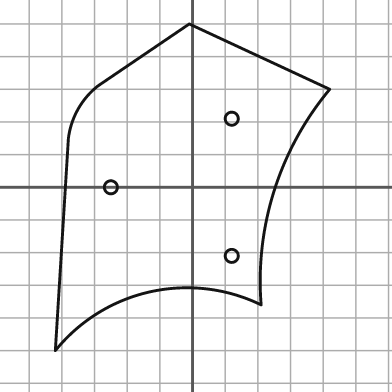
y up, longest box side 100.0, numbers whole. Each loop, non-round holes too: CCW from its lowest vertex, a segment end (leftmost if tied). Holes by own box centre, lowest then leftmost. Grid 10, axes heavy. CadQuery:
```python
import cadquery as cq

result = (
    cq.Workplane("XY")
    .moveTo(-42.0, -50.0)
    .threePointArc((-13.0, -32.0), (21.0, -36.0))
    .threePointArc((25.0, -1.0), (42.0, 30.0))
    .lineTo(-1.0, 50.0)
    .lineTo(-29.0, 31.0)
    .threePointArc((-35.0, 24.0), (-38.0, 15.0))
    .close()
    .moveTo(12.0, -21.0)
    .circle(2.0)
    .moveTo(-25.0, 0.0)
    .circle(2.0)
    .moveTo(12.0, 21.0)
    .circle(2.0)
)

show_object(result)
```